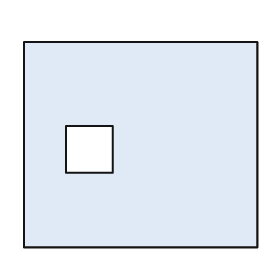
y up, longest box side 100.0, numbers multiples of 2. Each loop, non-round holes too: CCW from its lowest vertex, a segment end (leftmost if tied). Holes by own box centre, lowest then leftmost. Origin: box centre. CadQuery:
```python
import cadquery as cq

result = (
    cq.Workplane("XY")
    .moveTo(-50.0, -44.0)
    .lineTo(50.0, -44.0)
    .lineTo(50.0, 44.0)
    .lineTo(-50.0, 44.0)
    .close()
    .moveTo(-32.0, -12.0)
    .lineTo(-12.0, -12.0)
    .lineTo(-12.0, 8.0)
    .lineTo(-32.0, 8.0)
    .close()
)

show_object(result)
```